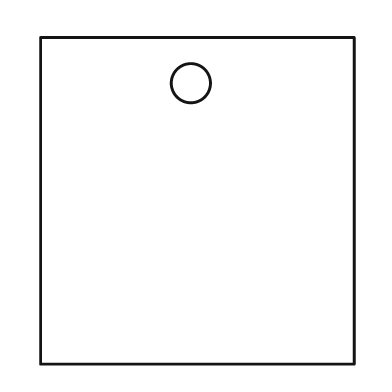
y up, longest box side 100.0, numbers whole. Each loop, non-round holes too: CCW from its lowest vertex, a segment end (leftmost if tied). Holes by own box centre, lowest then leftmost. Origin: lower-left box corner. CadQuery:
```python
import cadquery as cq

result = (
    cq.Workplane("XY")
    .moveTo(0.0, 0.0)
    .lineTo(96.0, 0.0)
    .lineTo(96.0, 100.0)
    .lineTo(0.0, 100.0)
    .close()
    .moveTo(46.0, 86.0)
    .circle(6.0)
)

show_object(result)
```